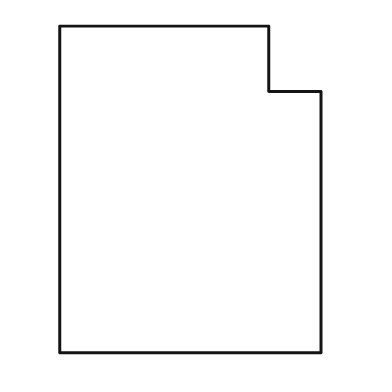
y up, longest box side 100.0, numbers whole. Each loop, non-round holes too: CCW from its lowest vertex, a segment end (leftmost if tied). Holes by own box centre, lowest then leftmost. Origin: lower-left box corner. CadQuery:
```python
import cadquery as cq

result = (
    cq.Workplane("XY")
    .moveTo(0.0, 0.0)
    .lineTo(80.0, 0.0)
    .lineTo(80.0, 80.0)
    .lineTo(64.0, 80.0)
    .lineTo(64.0, 100.0)
    .lineTo(0.0, 100.0)
    .close()
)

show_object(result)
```